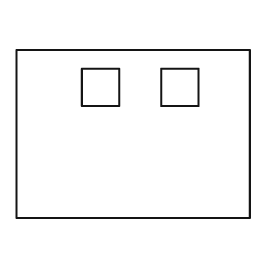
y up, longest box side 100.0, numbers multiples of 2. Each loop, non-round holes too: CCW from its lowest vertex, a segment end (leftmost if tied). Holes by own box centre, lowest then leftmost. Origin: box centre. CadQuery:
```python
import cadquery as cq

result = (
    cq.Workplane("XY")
    .moveTo(-50.0, -36.0)
    .lineTo(50.0, -36.0)
    .lineTo(50.0, 36.0)
    .lineTo(-50.0, 36.0)
    .close()
    .moveTo(-22.0, 12.0)
    .lineTo(-6.0, 12.0)
    .lineTo(-6.0, 28.0)
    .lineTo(-22.0, 28.0)
    .close()
    .moveTo(12.0, 12.0)
    .lineTo(28.0, 12.0)
    .lineTo(28.0, 28.0)
    .lineTo(12.0, 28.0)
    .close()
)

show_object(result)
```